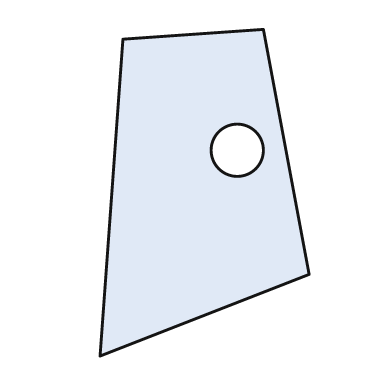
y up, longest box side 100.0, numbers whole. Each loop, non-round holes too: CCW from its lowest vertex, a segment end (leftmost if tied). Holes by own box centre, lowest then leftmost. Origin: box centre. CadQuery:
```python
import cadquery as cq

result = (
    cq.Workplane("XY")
    .moveTo(-32.0, -50.0)
    .lineTo(32.0, -25.0)
    .lineTo(18.0, 50.0)
    .lineTo(-25.0, 47.0)
    .close()
    .moveTo(10.0, 13.0)
    .circle(8.0)
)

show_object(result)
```